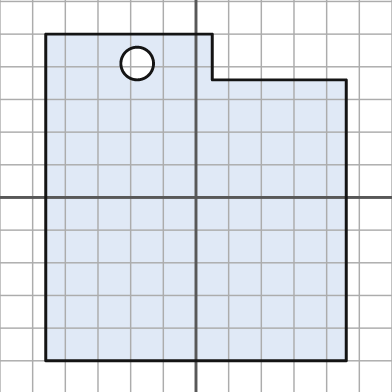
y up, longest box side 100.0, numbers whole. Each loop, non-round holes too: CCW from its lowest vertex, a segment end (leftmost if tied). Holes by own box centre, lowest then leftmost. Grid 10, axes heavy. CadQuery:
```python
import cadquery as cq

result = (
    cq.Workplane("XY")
    .moveTo(-46.0, -50.0)
    .lineTo(46.0, -50.0)
    .lineTo(46.0, 36.0)
    .lineTo(5.0, 36.0)
    .lineTo(5.0, 50.0)
    .lineTo(-46.0, 50.0)
    .close()
    .moveTo(-18.0, 41.0)
    .circle(5.0)
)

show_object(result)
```